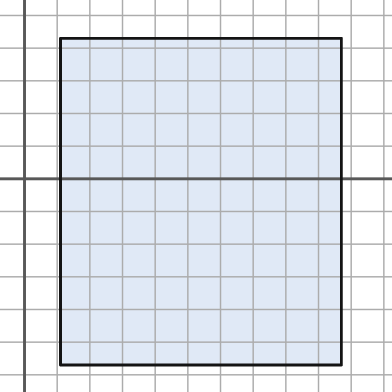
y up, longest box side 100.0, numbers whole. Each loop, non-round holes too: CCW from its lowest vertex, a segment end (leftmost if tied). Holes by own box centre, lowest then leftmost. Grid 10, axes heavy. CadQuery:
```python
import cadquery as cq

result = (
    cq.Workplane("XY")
    .moveTo(11.0, -57.0)
    .lineTo(97.0, -57.0)
    .lineTo(97.0, 43.0)
    .lineTo(11.0, 43.0)
    .close()
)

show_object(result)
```